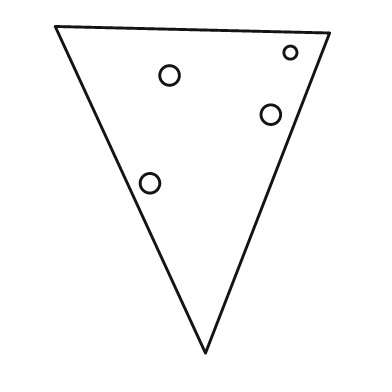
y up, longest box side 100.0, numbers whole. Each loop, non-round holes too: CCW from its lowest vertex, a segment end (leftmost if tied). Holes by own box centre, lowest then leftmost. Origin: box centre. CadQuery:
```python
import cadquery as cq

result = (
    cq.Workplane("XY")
    .moveTo(4.0, -50.0)
    .lineTo(42.0, 48.0)
    .lineTo(-42.0, 50.0)
    .close()
    .moveTo(-13.0, 2.0)
    .circle(3.0)
    .moveTo(24.0, 23.0)
    .circle(3.0)
    .moveTo(-7.0, 35.0)
    .circle(3.0)
    .moveTo(30.0, 42.0)
    .circle(2.0)
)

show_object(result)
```